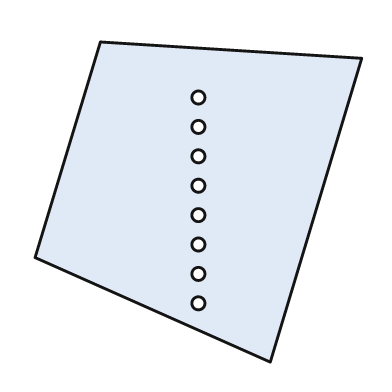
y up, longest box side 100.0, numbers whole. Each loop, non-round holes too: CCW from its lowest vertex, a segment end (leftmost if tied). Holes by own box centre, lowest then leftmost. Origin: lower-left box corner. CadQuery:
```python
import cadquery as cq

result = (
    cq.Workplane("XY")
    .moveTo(72.0, 0.0)
    .lineTo(100.0, 93.0)
    .lineTo(20.0, 98.0)
    .lineTo(0.0, 32.0)
    .close()
    .moveTo(50.0, 18.0)
    .circle(2.0)
    .moveTo(50.0, 27.0)
    .circle(2.0)
    .moveTo(50.0, 36.0)
    .circle(2.0)
    .moveTo(50.0, 45.0)
    .circle(2.0)
    .moveTo(50.0, 54.0)
    .circle(2.0)
    .moveTo(50.0, 63.0)
    .circle(2.0)
    .moveTo(50.0, 72.0)
    .circle(2.0)
    .moveTo(50.0, 81.0)
    .circle(2.0)
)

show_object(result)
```